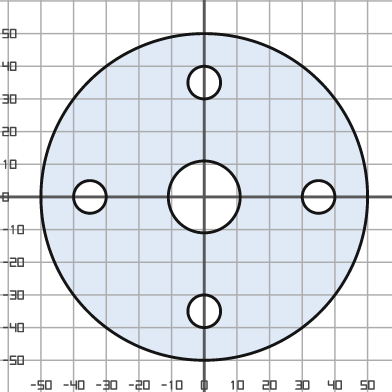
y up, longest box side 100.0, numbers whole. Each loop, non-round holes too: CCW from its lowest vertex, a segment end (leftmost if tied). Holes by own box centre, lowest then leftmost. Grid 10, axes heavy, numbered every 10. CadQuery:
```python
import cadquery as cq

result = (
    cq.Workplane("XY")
    .moveTo(0.0, 0.0)
    .circle(50.0)
    .moveTo(0.0, -35.0)
    .circle(5.0)
    .moveTo(-35.0, 0.0)
    .circle(5.0)
    .moveTo(0.0, 0.0)
    .circle(11.0)
    .moveTo(35.0, 0.0)
    .circle(5.0)
    .moveTo(0.0, 35.0)
    .circle(5.0)
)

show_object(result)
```